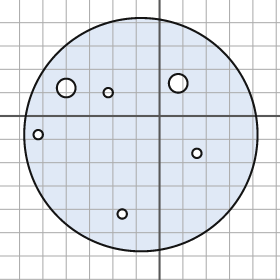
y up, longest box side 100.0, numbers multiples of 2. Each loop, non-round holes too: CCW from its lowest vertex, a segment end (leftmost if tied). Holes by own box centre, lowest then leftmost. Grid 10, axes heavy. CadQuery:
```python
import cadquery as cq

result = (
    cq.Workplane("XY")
    .moveTo(-8.0, -8.0)
    .circle(50.0)
    .moveTo(-16.0, -42.0)
    .circle(2.0)
    .moveTo(16.0, -16.0)
    .circle(2.0)
    .moveTo(-52.0, -8.0)
    .circle(2.0)
    .moveTo(-22.0, 10.0)
    .circle(2.0)
    .moveTo(-40.0, 12.0)
    .circle(4.0)
    .moveTo(8.0, 14.0)
    .circle(4.0)
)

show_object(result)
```